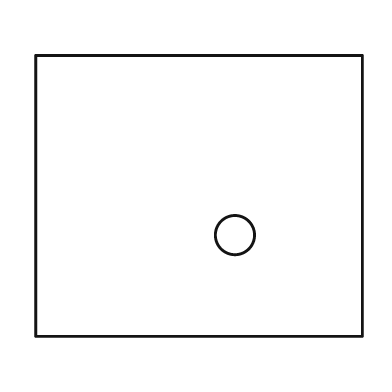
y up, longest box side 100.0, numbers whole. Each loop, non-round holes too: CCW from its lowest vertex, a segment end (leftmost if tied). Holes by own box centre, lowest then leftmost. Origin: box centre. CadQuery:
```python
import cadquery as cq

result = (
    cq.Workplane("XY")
    .moveTo(-50.0, -43.0)
    .lineTo(50.0, -43.0)
    .lineTo(50.0, 43.0)
    .lineTo(-50.0, 43.0)
    .close()
    .moveTo(11.0, -12.0)
    .circle(6.0)
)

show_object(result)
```